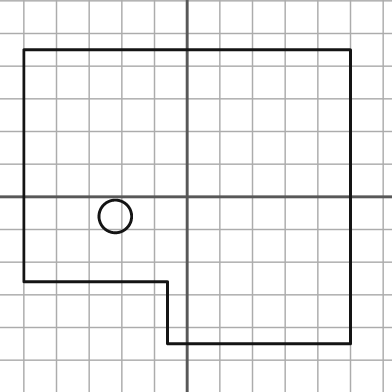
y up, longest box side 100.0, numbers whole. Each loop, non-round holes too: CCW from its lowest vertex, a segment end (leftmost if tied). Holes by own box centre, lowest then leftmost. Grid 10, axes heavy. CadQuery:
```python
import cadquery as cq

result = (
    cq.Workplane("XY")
    .moveTo(-6.0, -45.0)
    .lineTo(50.0, -45.0)
    .lineTo(50.0, 45.0)
    .lineTo(-50.0, 45.0)
    .lineTo(-50.0, -26.0)
    .lineTo(-6.0, -26.0)
    .close()
    .moveTo(-22.0, -6.0)
    .circle(5.0)
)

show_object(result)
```